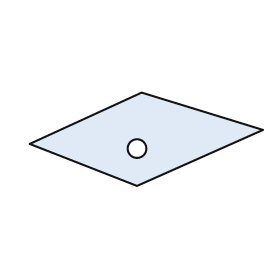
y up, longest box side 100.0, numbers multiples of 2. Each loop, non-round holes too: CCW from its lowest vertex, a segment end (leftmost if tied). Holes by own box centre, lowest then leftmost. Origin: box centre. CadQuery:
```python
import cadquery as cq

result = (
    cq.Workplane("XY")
    .moveTo(-4.0, -20.0)
    .lineTo(50.0, 4.0)
    .lineTo(-2.0, 20.0)
    .lineTo(-50.0, -2.0)
    .close()
    .moveTo(-4.0, -4.0)
    .circle(4.0)
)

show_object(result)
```